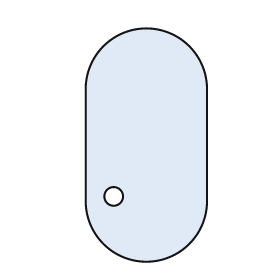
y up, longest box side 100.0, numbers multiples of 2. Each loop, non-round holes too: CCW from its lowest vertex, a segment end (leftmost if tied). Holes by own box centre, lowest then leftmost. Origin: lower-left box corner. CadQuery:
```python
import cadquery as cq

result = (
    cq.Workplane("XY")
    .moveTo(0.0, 26.0)
    .threePointArc((26.0, 0.0), (52.0, 26.0))
    .lineTo(52.0, 74.0)
    .threePointArc((26.0, 100.0), (0.0, 74.0))
    .close()
    .moveTo(12.0, 28.0)
    .circle(4.0)
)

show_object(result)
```